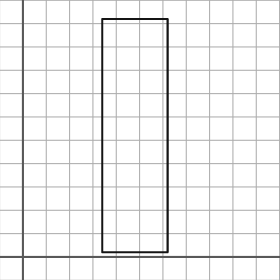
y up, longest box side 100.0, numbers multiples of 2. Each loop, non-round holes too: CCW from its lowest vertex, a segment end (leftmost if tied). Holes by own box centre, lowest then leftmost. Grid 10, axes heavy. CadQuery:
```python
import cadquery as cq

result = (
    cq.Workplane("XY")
    .moveTo(34.0, 2.0)
    .lineTo(62.0, 2.0)
    .lineTo(62.0, 102.0)
    .lineTo(34.0, 102.0)
    .close()
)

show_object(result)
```